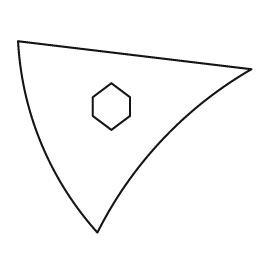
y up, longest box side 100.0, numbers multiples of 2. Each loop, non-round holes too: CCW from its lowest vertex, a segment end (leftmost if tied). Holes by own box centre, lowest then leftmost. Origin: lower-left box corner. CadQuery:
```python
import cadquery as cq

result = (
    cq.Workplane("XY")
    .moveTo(34.0, 0.0)
    .threePointArc((62.0, 40.0), (100.0, 70.0))
    .lineTo(0.0, 82.0)
    .threePointArc((10.0, 38.0), (34.0, 0.0))
    .close()
    .moveTo(40.0, 44.0)
    .lineTo(48.0, 50.0)
    .lineTo(48.0, 58.0)
    .lineTo(40.0, 64.0)
    .lineTo(32.0, 58.0)
    .lineTo(32.0, 50.0)
    .close()
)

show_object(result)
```